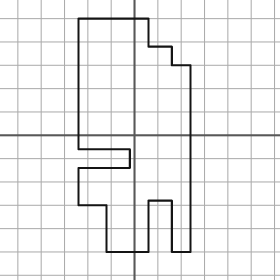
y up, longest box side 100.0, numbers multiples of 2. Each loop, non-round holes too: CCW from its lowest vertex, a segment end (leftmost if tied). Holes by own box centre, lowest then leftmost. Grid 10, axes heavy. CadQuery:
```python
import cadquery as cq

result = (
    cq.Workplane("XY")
    .moveTo(-12.0, -50.0)
    .lineTo(6.0, -50.0)
    .lineTo(6.0, -28.0)
    .lineTo(16.0, -28.0)
    .lineTo(16.0, -50.0)
    .lineTo(24.0, -50.0)
    .lineTo(24.0, 30.0)
    .lineTo(16.0, 30.0)
    .lineTo(16.0, 38.0)
    .lineTo(6.0, 38.0)
    .lineTo(6.0, 50.0)
    .lineTo(-24.0, 50.0)
    .lineTo(-24.0, -6.0)
    .lineTo(-2.0, -6.0)
    .lineTo(-2.0, -14.0)
    .lineTo(-24.0, -14.0)
    .lineTo(-24.0, -30.0)
    .lineTo(-12.0, -30.0)
    .close()
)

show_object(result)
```